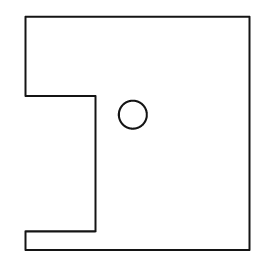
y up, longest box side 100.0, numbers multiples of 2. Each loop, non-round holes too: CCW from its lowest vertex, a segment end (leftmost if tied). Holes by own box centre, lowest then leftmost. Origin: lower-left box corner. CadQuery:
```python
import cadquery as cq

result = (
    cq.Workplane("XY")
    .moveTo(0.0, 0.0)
    .lineTo(96.0, 0.0)
    .lineTo(96.0, 100.0)
    .lineTo(0.0, 100.0)
    .lineTo(0.0, 66.0)
    .lineTo(30.0, 66.0)
    .lineTo(30.0, 8.0)
    .lineTo(0.0, 8.0)
    .close()
    .moveTo(46.0, 58.0)
    .circle(6.0)
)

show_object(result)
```